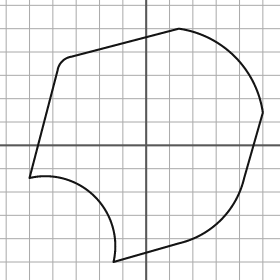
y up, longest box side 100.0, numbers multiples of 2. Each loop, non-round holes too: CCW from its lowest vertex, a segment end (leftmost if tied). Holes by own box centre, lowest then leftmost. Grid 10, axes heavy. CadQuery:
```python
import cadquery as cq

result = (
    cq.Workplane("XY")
    .moveTo(-14.0, -50.0)
    .lineTo(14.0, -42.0)
    .threePointArc((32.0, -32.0), (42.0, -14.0))
    .lineTo(50.0, 14.0)
    .threePointArc((38.0, 38.0), (14.0, 50.0))
    .lineTo(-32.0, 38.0)
    .threePointArc((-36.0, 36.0), (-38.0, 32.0))
    .lineTo(-50.0, -14.0)
    .threePointArc((-22.0, -22.0), (-14.0, -50.0))
    .close()
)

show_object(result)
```